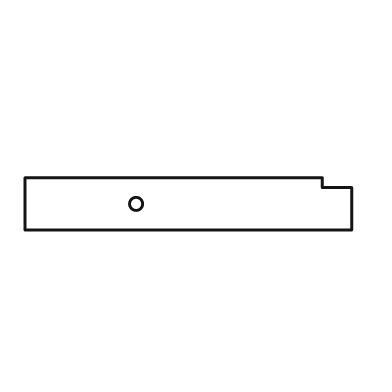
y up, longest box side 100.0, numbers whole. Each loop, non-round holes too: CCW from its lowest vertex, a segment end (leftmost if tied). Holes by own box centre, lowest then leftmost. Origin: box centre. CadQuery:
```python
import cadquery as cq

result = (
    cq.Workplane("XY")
    .moveTo(-50.0, -8.0)
    .lineTo(50.0, -8.0)
    .lineTo(50.0, 5.0)
    .lineTo(41.0, 5.0)
    .lineTo(41.0, 8.0)
    .lineTo(-50.0, 8.0)
    .close()
    .moveTo(-16.0, 0.0)
    .circle(2.0)
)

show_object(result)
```